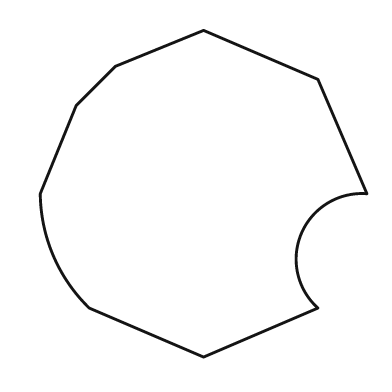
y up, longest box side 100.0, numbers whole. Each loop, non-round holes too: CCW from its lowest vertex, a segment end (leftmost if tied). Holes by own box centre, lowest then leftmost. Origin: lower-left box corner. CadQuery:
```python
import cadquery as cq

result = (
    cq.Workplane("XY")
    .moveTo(50.0, 0.0)
    .lineTo(85.0, 15.0)
    .threePointArc((80.0, 38.0), (100.0, 50.0))
    .lineTo(85.0, 85.0)
    .lineTo(50.0, 100.0)
    .lineTo(23.0, 89.0)
    .lineTo(11.0, 77.0)
    .lineTo(0.0, 50.0)
    .threePointArc((4.0, 31.0), (15.0, 15.0))
    .close()
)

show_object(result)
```